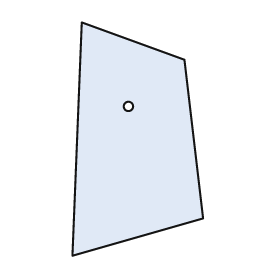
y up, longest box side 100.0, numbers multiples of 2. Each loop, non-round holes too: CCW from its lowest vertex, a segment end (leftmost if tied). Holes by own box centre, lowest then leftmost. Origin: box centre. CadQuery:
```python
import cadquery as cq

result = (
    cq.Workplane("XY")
    .moveTo(-28.0, -50.0)
    .lineTo(28.0, -34.0)
    .lineTo(20.0, 34.0)
    .lineTo(-24.0, 50.0)
    .close()
    .moveTo(-4.0, 14.0)
    .circle(2.0)
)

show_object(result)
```